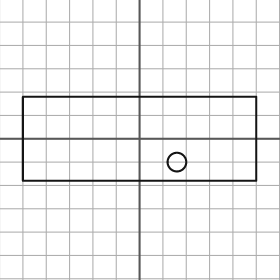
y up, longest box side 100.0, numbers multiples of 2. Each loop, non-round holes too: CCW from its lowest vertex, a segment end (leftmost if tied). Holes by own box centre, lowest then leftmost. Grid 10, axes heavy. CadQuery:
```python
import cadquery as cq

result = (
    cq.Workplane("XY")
    .moveTo(-50.0, -18.0)
    .lineTo(50.0, -18.0)
    .lineTo(50.0, 18.0)
    .lineTo(-50.0, 18.0)
    .close()
    .moveTo(16.0, -10.0)
    .circle(4.0)
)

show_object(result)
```